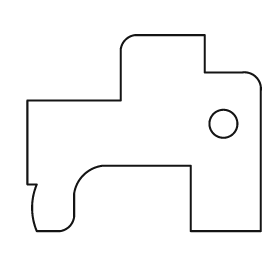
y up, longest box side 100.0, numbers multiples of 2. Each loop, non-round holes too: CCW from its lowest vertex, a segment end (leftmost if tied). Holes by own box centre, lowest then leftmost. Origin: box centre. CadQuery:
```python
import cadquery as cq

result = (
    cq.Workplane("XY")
    .moveTo(-46.0, -42.0)
    .lineTo(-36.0, -42.0)
    .threePointArc((-32.0, -40.0), (-30.0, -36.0))
    .lineTo(-30.0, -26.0)
    .threePointArc((-26.0, -18.0), (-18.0, -14.0))
    .lineTo(20.0, -14.0)
    .lineTo(20.0, -42.0)
    .lineTo(50.0, -42.0)
    .lineTo(50.0, 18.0)
    .threePointArc((48.0, 24.0), (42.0, 26.0))
    .lineTo(26.0, 26.0)
    .lineTo(26.0, 42.0)
    .lineTo(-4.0, 42.0)
    .threePointArc((-8.0, 40.0), (-10.0, 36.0))
    .lineTo(-10.0, 14.0)
    .lineTo(-50.0, 14.0)
    .lineTo(-50.0, -22.0)
    .lineTo(-46.0, -22.0)
    .threePointArc((-48.0, -32.0), (-46.0, -42.0))
    .close()
    .moveTo(34.0, 4.0)
    .circle(6.0)
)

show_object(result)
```